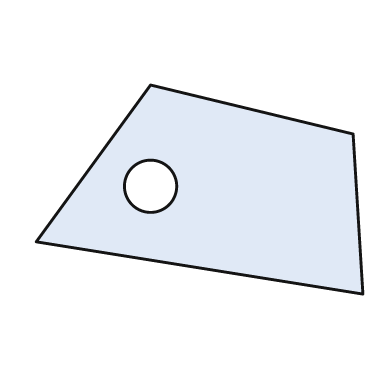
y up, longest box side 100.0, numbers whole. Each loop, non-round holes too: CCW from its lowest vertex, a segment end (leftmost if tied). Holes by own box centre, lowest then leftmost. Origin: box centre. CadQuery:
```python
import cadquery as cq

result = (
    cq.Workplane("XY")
    .moveTo(50.0, -32.0)
    .lineTo(47.0, 17.0)
    .lineTo(-15.0, 32.0)
    .lineTo(-50.0, -16.0)
    .close()
    .moveTo(-15.0, 1.0)
    .circle(8.0)
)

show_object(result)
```